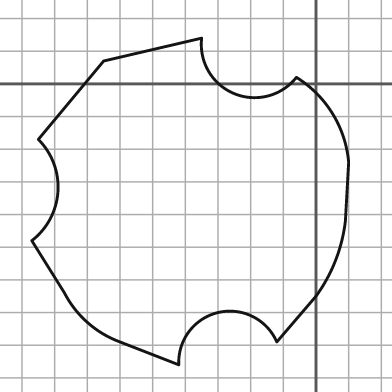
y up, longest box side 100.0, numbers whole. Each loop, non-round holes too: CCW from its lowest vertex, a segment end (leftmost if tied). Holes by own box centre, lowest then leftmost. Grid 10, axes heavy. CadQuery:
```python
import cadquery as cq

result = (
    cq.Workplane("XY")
    .moveTo(-42.0, -86.0)
    .threePointArc((-30.0, -70.0), (-12.0, -79.0))
    .lineTo(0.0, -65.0)
    .threePointArc((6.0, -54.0), (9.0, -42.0))
    .lineTo(10.0, -24.0)
    .threePointArc((5.0, -9.0), (-6.0, 2.0))
    .threePointArc((-25.0, -3.0), (-35.0, 14.0))
    .lineTo(-65.0, 7.0)
    .lineTo(-85.0, -17.0)
    .threePointArc((-79.0, -33.0), (-87.0, -48.0))
    .lineTo(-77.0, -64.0)
    .threePointArc((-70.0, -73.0), (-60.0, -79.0))
    .close()
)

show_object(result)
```